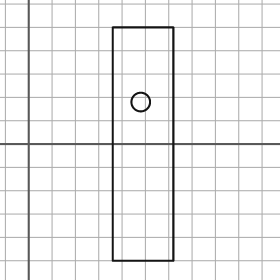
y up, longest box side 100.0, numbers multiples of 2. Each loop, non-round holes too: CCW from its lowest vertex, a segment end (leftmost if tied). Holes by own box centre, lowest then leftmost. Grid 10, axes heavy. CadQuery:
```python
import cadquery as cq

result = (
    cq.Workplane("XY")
    .moveTo(36.0, -50.0)
    .lineTo(62.0, -50.0)
    .lineTo(62.0, 50.0)
    .lineTo(36.0, 50.0)
    .close()
    .moveTo(48.0, 18.0)
    .circle(4.0)
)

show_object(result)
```